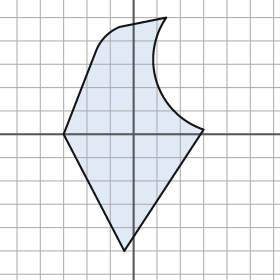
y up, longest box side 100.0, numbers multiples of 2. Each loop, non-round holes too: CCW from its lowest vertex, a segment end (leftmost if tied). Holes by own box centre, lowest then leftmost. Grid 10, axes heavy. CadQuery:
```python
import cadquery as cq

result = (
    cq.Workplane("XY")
    .moveTo(-4.0, -50.0)
    .lineTo(30.0, 2.0)
    .threePointArc((10.0, 22.0), (14.0, 50.0))
    .lineTo(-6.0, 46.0)
    .threePointArc((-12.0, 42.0), (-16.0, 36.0))
    .lineTo(-30.0, 0.0)
    .close()
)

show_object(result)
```